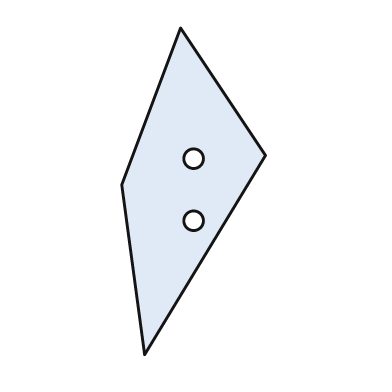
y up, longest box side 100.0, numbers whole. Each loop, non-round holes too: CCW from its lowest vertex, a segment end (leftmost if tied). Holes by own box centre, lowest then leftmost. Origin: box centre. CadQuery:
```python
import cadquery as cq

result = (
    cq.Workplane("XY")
    .moveTo(-15.0, -50.0)
    .lineTo(22.0, 11.0)
    .lineTo(-4.0, 50.0)
    .lineTo(-22.0, 2.0)
    .close()
    .moveTo(0.0, -9.0)
    .circle(3.0)
    .moveTo(0.0, 10.0)
    .circle(3.0)
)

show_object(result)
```